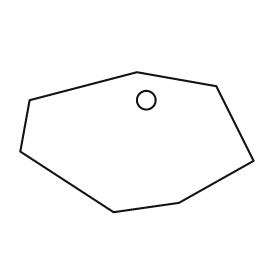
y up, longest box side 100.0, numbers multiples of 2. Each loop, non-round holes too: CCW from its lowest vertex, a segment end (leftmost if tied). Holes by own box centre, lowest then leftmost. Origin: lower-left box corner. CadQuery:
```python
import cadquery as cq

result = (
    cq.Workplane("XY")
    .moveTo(40.0, 0.0)
    .lineTo(68.0, 4.0)
    .lineTo(100.0, 22.0)
    .lineTo(84.0, 54.0)
    .lineTo(50.0, 60.0)
    .lineTo(4.0, 48.0)
    .lineTo(0.0, 26.0)
    .close()
    .moveTo(54.0, 48.0)
    .circle(4.0)
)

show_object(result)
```